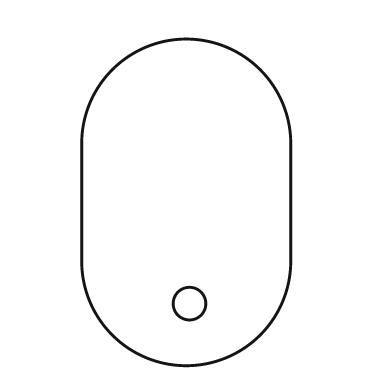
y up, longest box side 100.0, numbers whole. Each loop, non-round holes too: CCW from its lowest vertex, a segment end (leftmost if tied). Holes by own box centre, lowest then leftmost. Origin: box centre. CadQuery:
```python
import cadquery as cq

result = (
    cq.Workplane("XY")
    .moveTo(-32.0, -18.0)
    .threePointArc((0.0, -50.0), (32.0, -18.0))
    .lineTo(32.0, 18.0)
    .threePointArc((0.0, 50.0), (-32.0, 18.0))
    .close()
    .moveTo(1.0, -31.0)
    .circle(5.0)
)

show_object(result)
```